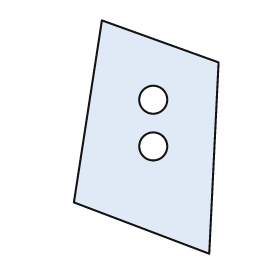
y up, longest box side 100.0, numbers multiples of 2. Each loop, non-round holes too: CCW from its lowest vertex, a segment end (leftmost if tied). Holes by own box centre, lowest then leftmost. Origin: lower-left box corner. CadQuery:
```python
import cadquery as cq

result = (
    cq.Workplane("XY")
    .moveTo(58.0, 0.0)
    .lineTo(62.0, 82.0)
    .lineTo(12.0, 100.0)
    .lineTo(0.0, 22.0)
    .close()
    .moveTo(34.0, 46.0)
    .circle(6.0)
    .moveTo(34.0, 66.0)
    .circle(6.0)
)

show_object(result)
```